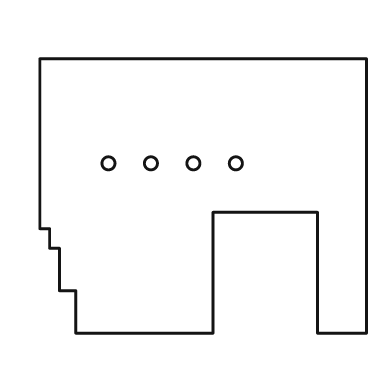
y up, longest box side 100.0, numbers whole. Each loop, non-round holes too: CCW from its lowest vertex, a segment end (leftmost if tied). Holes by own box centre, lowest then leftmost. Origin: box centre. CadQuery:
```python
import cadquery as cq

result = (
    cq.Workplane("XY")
    .moveTo(-39.0, -42.0)
    .lineTo(3.0, -42.0)
    .lineTo(3.0, -5.0)
    .lineTo(35.0, -5.0)
    .lineTo(35.0, -42.0)
    .lineTo(50.0, -42.0)
    .lineTo(50.0, 42.0)
    .lineTo(-50.0, 42.0)
    .lineTo(-50.0, -10.0)
    .lineTo(-47.0, -10.0)
    .lineTo(-47.0, -16.0)
    .lineTo(-44.0, -16.0)
    .lineTo(-44.0, -29.0)
    .lineTo(-39.0, -29.0)
    .close()
    .moveTo(-29.0, 10.0)
    .circle(2.0)
    .moveTo(-16.0, 10.0)
    .circle(2.0)
    .moveTo(-3.0, 10.0)
    .circle(2.0)
    .moveTo(10.0, 10.0)
    .circle(2.0)
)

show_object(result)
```